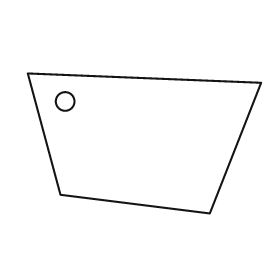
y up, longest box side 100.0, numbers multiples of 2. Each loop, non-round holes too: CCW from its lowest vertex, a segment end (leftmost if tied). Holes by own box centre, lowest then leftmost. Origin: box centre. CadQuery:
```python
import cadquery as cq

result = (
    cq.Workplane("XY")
    .moveTo(28.0, -30.0)
    .lineTo(50.0, 26.0)
    .lineTo(-50.0, 30.0)
    .lineTo(-36.0, -22.0)
    .close()
    .moveTo(-34.0, 18.0)
    .circle(4.0)
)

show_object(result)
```